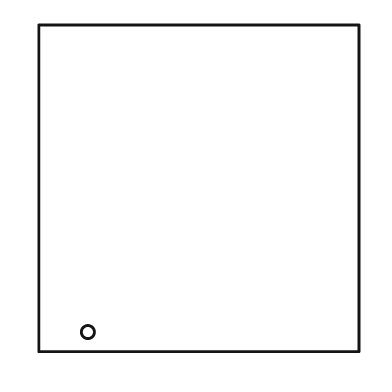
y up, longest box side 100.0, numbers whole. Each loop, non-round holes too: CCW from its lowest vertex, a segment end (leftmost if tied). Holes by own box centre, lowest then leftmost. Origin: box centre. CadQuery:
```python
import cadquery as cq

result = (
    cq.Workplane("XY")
    .moveTo(-49.0, -50.0)
    .lineTo(49.0, -50.0)
    .lineTo(49.0, 50.0)
    .lineTo(-49.0, 50.0)
    .close()
    .moveTo(-34.0, -44.0)
    .circle(2.0)
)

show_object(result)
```